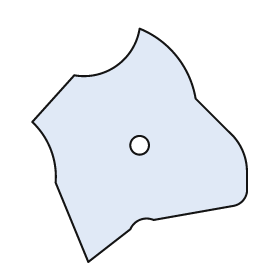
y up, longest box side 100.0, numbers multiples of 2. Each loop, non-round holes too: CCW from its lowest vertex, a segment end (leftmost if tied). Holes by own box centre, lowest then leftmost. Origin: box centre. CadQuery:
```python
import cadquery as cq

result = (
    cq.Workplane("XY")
    .moveTo(-22.0, -50.0)
    .lineTo(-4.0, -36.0)
    .threePointArc((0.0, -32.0), (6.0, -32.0))
    .lineTo(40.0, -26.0)
    .threePointArc((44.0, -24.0), (46.0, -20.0))
    .lineTo(46.0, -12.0)
    .threePointArc((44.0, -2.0), (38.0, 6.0))
    .lineTo(24.0, 20.0)
    .threePointArc((16.0, 38.0), (0.0, 50.0))
    .threePointArc((-10.0, 34.0), (-28.0, 30.0))
    .lineTo(-46.0, 10.0)
    .threePointArc((-38.0, -2.0), (-36.0, -16.0))
    .close()
    .moveTo(0.0, 0.0)
    .circle(4.0)
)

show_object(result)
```